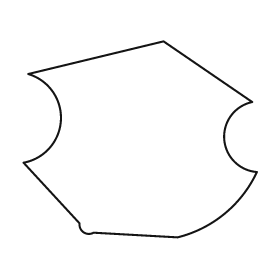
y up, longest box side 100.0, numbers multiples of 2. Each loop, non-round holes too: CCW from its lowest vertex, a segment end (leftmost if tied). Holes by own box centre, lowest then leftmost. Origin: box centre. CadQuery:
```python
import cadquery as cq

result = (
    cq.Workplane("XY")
    .moveTo(16.0, -42.0)
    .threePointArc((36.0, -32.0), (50.0, -14.0))
    .threePointArc((36.0, 0.0), (48.0, 16.0))
    .lineTo(10.0, 42.0)
    .lineTo(-48.0, 28.0)
    .threePointArc((-34.0, 8.0), (-50.0, -10.0))
    .lineTo(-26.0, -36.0)
    .threePointArc((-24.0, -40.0), (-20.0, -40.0))
    .close()
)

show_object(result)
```